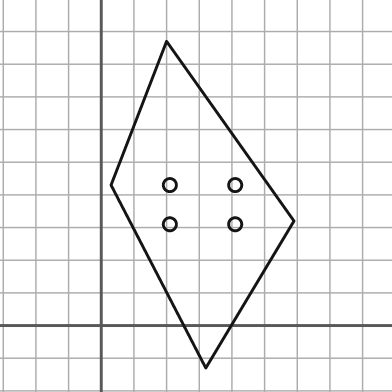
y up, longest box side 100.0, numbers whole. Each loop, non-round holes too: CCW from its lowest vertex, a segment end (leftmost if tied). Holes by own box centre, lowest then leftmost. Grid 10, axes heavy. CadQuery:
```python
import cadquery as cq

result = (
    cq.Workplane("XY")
    .moveTo(32.0, -13.0)
    .lineTo(59.0, 32.0)
    .lineTo(20.0, 87.0)
    .lineTo(3.0, 43.0)
    .close()
    .moveTo(21.0, 31.0)
    .circle(2.0)
    .moveTo(41.0, 31.0)
    .circle(2.0)
    .moveTo(21.0, 43.0)
    .circle(2.0)
    .moveTo(41.0, 43.0)
    .circle(2.0)
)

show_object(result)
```